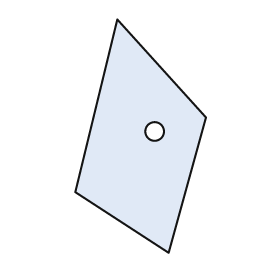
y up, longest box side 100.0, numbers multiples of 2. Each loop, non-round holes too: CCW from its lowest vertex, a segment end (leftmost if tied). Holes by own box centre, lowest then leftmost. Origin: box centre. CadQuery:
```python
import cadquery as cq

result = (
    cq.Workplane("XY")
    .moveTo(12.0, -50.0)
    .lineTo(28.0, 8.0)
    .lineTo(-10.0, 50.0)
    .lineTo(-28.0, -24.0)
    .close()
    .moveTo(6.0, 2.0)
    .circle(4.0)
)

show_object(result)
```